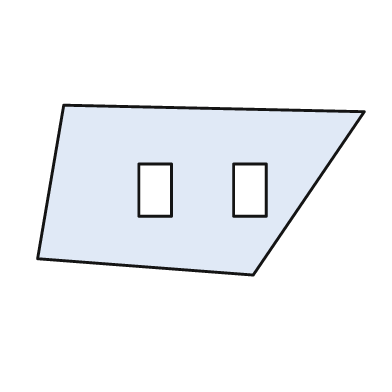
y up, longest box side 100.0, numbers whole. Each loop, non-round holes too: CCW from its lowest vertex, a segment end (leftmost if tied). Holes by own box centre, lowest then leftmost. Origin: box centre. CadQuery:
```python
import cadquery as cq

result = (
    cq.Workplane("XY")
    .moveTo(16.0, -26.0)
    .lineTo(50.0, 24.0)
    .lineTo(-42.0, 26.0)
    .lineTo(-50.0, -21.0)
    .close()
    .moveTo(-19.0, -8.0)
    .lineTo(-9.0, -8.0)
    .lineTo(-9.0, 8.0)
    .lineTo(-19.0, 8.0)
    .close()
    .moveTo(10.0, -8.0)
    .lineTo(20.0, -8.0)
    .lineTo(20.0, 8.0)
    .lineTo(10.0, 8.0)
    .close()
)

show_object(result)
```